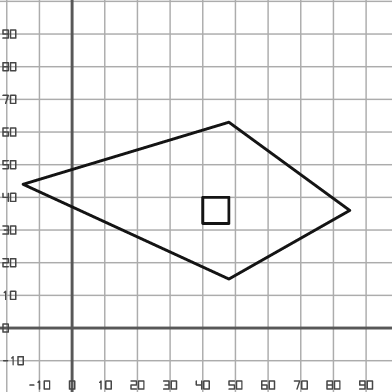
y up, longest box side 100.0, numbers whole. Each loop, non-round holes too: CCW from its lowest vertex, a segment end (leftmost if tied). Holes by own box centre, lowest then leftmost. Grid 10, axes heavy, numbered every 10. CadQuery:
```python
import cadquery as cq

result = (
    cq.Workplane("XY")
    .moveTo(48.0, 15.0)
    .lineTo(85.0, 36.0)
    .lineTo(48.0, 63.0)
    .lineTo(-15.0, 44.0)
    .close()
    .moveTo(40.0, 32.0)
    .lineTo(48.0, 32.0)
    .lineTo(48.0, 40.0)
    .lineTo(40.0, 40.0)
    .close()
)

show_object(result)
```